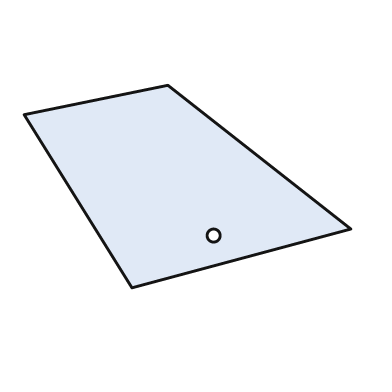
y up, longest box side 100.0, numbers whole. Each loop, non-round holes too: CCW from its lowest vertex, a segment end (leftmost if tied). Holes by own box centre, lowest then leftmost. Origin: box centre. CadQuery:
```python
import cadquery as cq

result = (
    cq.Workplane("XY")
    .moveTo(-17.0, -31.0)
    .lineTo(50.0, -13.0)
    .lineTo(-6.0, 31.0)
    .lineTo(-50.0, 22.0)
    .close()
    .moveTo(8.0, -15.0)
    .circle(2.0)
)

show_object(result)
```